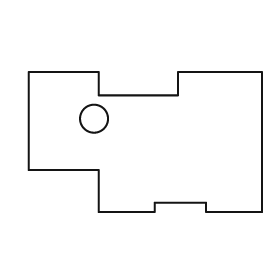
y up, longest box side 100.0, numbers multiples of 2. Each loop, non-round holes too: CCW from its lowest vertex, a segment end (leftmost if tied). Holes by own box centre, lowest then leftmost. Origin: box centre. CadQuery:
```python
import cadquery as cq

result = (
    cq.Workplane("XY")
    .moveTo(-20.0, -30.0)
    .lineTo(4.0, -30.0)
    .lineTo(4.0, -26.0)
    .lineTo(26.0, -26.0)
    .lineTo(26.0, -30.0)
    .lineTo(50.0, -30.0)
    .lineTo(50.0, 30.0)
    .lineTo(14.0, 30.0)
    .lineTo(14.0, 20.0)
    .lineTo(-20.0, 20.0)
    .lineTo(-20.0, 30.0)
    .lineTo(-50.0, 30.0)
    .lineTo(-50.0, -12.0)
    .lineTo(-20.0, -12.0)
    .close()
    .moveTo(-22.0, 10.0)
    .circle(6.0)
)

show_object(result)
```